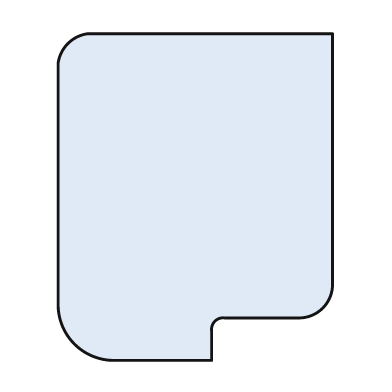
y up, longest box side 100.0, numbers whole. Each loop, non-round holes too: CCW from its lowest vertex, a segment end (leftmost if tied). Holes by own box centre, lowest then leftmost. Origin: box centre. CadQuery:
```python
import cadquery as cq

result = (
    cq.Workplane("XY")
    .moveTo(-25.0, -50.0)
    .lineTo(5.0, -50.0)
    .lineTo(5.0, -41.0)
    .threePointArc((6.0, -38.0), (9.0, -37.0))
    .lineTo(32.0, -37.0)
    .threePointArc((39.0, -34.0), (42.0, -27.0))
    .lineTo(42.0, 50.0)
    .lineTo(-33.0, 50.0)
    .threePointArc((-39.0, 47.0), (-42.0, 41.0))
    .lineTo(-42.0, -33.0)
    .threePointArc((-37.0, -45.0), (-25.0, -50.0))
    .close()
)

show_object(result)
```